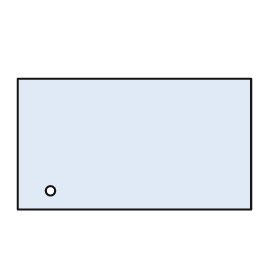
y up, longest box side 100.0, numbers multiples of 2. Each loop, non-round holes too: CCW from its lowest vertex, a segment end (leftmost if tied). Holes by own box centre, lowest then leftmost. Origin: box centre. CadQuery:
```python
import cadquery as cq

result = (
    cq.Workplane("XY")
    .moveTo(-50.0, -28.0)
    .lineTo(50.0, -28.0)
    .lineTo(50.0, 28.0)
    .lineTo(-50.0, 28.0)
    .close()
    .moveTo(-36.0, -20.0)
    .circle(2.0)
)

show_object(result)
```